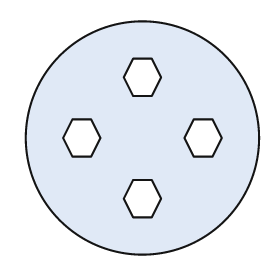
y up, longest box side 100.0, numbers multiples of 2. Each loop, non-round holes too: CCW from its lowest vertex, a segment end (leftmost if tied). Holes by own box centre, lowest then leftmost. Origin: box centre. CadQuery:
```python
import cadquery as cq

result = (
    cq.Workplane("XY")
    .moveTo(0.0, 0.0)
    .circle(50.0)
    .moveTo(-4.0, -34.0)
    .lineTo(4.0, -34.0)
    .lineTo(8.0, -26.0)
    .lineTo(4.0, -18.0)
    .lineTo(-4.0, -18.0)
    .lineTo(-8.0, -26.0)
    .close()
    .moveTo(-30.0, -8.0)
    .lineTo(-22.0, -8.0)
    .lineTo(-18.0, 0.0)
    .lineTo(-22.0, 8.0)
    .lineTo(-30.0, 8.0)
    .lineTo(-34.0, 0.0)
    .close()
    .moveTo(22.0, -8.0)
    .lineTo(30.0, -8.0)
    .lineTo(34.0, 0.0)
    .lineTo(30.0, 8.0)
    .lineTo(22.0, 8.0)
    .lineTo(18.0, 0.0)
    .close()
    .moveTo(-4.0, 18.0)
    .lineTo(4.0, 18.0)
    .lineTo(8.0, 26.0)
    .lineTo(4.0, 34.0)
    .lineTo(-4.0, 34.0)
    .lineTo(-8.0, 26.0)
    .close()
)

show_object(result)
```